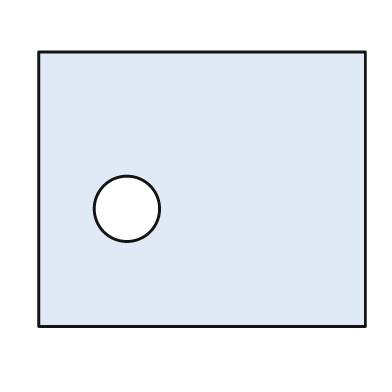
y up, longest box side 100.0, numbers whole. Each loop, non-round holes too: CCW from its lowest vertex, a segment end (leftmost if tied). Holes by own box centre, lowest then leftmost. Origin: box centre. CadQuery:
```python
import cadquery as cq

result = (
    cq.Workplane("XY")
    .moveTo(-50.0, -42.0)
    .lineTo(50.0, -42.0)
    .lineTo(50.0, 42.0)
    .lineTo(-50.0, 42.0)
    .close()
    .moveTo(-23.0, -6.0)
    .circle(10.0)
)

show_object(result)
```